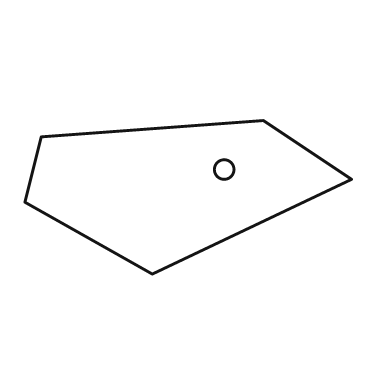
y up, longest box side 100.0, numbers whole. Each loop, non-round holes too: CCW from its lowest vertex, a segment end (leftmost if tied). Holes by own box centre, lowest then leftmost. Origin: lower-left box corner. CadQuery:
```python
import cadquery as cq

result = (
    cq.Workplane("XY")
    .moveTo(39.0, 0.0)
    .lineTo(100.0, 29.0)
    .lineTo(73.0, 47.0)
    .lineTo(5.0, 42.0)
    .lineTo(0.0, 22.0)
    .close()
    .moveTo(61.0, 32.0)
    .circle(3.0)
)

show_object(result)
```